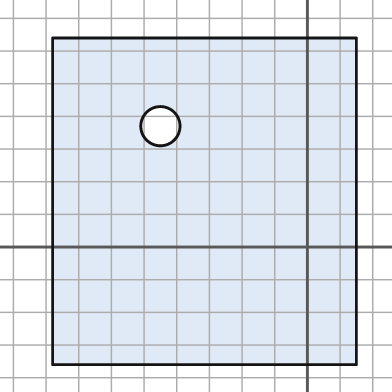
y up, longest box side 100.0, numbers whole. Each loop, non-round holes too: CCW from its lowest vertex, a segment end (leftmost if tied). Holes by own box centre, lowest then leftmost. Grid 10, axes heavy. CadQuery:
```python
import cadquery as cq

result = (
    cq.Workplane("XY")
    .moveTo(-78.0, -36.0)
    .lineTo(15.0, -36.0)
    .lineTo(15.0, 64.0)
    .lineTo(-78.0, 64.0)
    .close()
    .moveTo(-45.0, 37.0)
    .circle(6.0)
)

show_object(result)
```